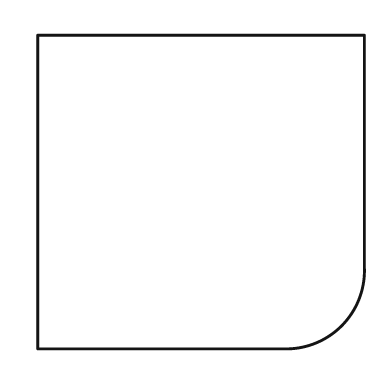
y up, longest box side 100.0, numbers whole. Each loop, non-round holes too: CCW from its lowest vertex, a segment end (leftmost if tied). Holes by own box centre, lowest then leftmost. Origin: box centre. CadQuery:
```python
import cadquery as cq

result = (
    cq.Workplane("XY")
    .moveTo(-50.0, -48.0)
    .lineTo(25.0, -48.0)
    .threePointArc((43.0, -41.0), (50.0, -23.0))
    .lineTo(50.0, 48.0)
    .lineTo(-50.0, 48.0)
    .close()
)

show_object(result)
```